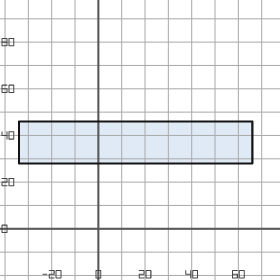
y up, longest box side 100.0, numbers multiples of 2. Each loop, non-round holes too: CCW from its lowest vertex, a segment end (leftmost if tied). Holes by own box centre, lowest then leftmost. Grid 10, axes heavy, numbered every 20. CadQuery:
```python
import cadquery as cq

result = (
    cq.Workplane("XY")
    .moveTo(-34.0, 28.0)
    .lineTo(66.0, 28.0)
    .lineTo(66.0, 46.0)
    .lineTo(-34.0, 46.0)
    .close()
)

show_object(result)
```